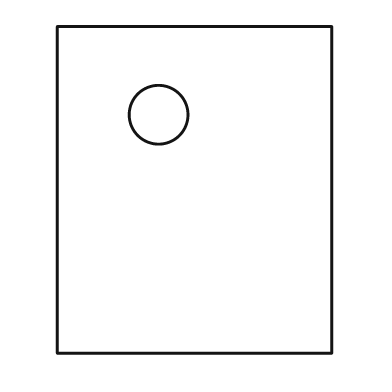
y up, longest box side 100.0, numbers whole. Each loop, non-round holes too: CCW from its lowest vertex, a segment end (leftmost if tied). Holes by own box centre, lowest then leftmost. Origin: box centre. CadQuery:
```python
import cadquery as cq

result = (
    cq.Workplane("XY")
    .moveTo(-42.0, -50.0)
    .lineTo(42.0, -50.0)
    .lineTo(42.0, 50.0)
    .lineTo(-42.0, 50.0)
    .close()
    .moveTo(-11.0, 23.0)
    .circle(9.0)
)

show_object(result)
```